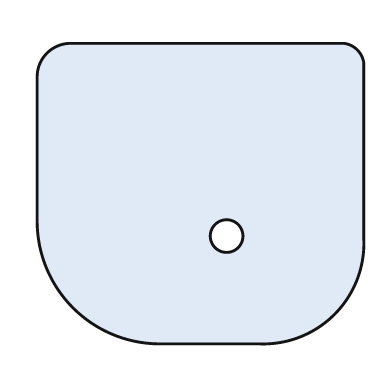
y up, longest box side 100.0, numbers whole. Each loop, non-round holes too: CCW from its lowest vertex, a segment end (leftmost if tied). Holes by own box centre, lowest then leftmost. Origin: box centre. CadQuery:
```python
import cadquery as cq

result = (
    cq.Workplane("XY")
    .moveTo(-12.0, -46.0)
    .lineTo(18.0, -46.0)
    .threePointArc((41.0, -37.0), (50.0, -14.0))
    .lineTo(50.0, 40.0)
    .threePointArc((48.0, 44.0), (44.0, 46.0))
    .lineTo(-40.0, 46.0)
    .threePointArc((-47.0, 43.0), (-50.0, 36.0))
    .lineTo(-50.0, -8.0)
    .threePointArc((-39.0, -35.0), (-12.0, -46.0))
    .close()
    .moveTo(8.0, -13.0)
    .circle(5.0)
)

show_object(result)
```